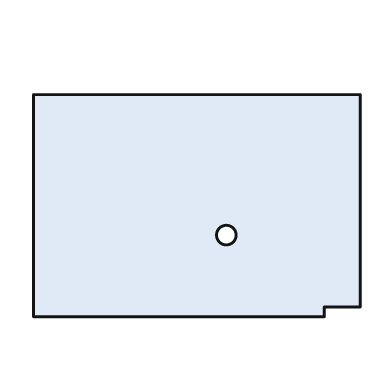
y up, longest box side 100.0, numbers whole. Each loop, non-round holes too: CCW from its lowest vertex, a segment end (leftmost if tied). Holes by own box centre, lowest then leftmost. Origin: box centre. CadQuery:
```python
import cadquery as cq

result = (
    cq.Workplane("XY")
    .moveTo(-50.0, -34.0)
    .lineTo(39.0, -34.0)
    .lineTo(39.0, -31.0)
    .lineTo(50.0, -31.0)
    .lineTo(50.0, 34.0)
    .lineTo(-50.0, 34.0)
    .close()
    .moveTo(9.0, -9.0)
    .circle(3.0)
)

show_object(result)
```